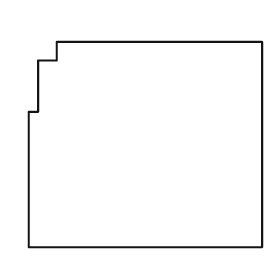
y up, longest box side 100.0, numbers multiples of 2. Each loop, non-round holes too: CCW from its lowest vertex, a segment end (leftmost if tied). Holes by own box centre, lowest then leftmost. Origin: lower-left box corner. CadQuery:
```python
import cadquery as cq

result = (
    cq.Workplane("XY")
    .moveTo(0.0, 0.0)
    .lineTo(100.0, 0.0)
    .lineTo(100.0, 88.0)
    .lineTo(12.0, 88.0)
    .lineTo(12.0, 80.0)
    .lineTo(4.0, 80.0)
    .lineTo(4.0, 58.0)
    .lineTo(0.0, 58.0)
    .close()
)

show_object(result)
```